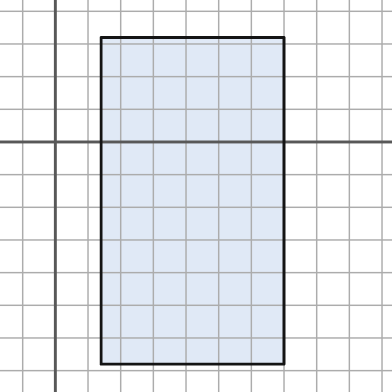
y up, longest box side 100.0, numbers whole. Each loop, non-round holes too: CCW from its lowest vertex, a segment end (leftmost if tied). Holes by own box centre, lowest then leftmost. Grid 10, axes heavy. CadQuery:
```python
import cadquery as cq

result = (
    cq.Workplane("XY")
    .moveTo(14.0, -68.0)
    .lineTo(70.0, -68.0)
    .lineTo(70.0, 32.0)
    .lineTo(14.0, 32.0)
    .close()
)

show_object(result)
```